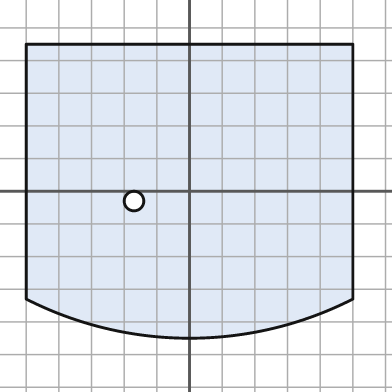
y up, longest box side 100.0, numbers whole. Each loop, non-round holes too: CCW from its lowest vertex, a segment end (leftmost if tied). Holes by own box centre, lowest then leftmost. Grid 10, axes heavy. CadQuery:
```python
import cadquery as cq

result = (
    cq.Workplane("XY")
    .moveTo(-50.0, -33.0)
    .threePointArc((0.0, -45.0), (50.0, -33.0))
    .lineTo(50.0, 45.0)
    .lineTo(-50.0, 45.0)
    .close()
    .moveTo(-17.0, -3.0)
    .circle(3.0)
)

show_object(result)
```